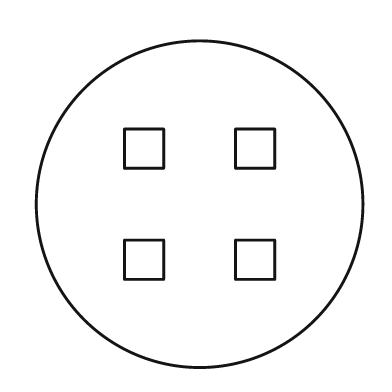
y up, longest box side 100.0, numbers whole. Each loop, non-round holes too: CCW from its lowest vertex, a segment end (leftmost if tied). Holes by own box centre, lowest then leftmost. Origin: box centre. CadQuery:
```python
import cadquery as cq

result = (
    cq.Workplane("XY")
    .moveTo(0.0, 0.0)
    .circle(50.0)
    .moveTo(-23.0, -23.0)
    .lineTo(-11.0, -23.0)
    .lineTo(-11.0, -11.0)
    .lineTo(-23.0, -11.0)
    .close()
    .moveTo(11.0, -23.0)
    .lineTo(23.0, -23.0)
    .lineTo(23.0, -11.0)
    .lineTo(11.0, -11.0)
    .close()
    .moveTo(-23.0, 11.0)
    .lineTo(-11.0, 11.0)
    .lineTo(-11.0, 23.0)
    .lineTo(-23.0, 23.0)
    .close()
    .moveTo(11.0, 11.0)
    .lineTo(23.0, 11.0)
    .lineTo(23.0, 23.0)
    .lineTo(11.0, 23.0)
    .close()
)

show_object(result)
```